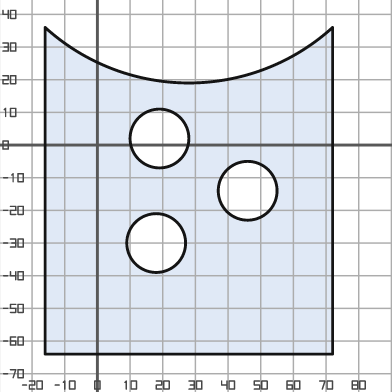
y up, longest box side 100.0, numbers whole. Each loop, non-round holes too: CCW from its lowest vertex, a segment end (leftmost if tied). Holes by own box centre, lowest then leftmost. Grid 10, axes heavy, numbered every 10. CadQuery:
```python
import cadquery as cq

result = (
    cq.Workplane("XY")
    .moveTo(-16.0, -64.0)
    .lineTo(72.0, -64.0)
    .lineTo(72.0, 36.0)
    .threePointArc((28.0, 19.0), (-16.0, 36.0))
    .close()
    .moveTo(18.0, -30.0)
    .circle(9.0)
    .moveTo(46.0, -14.0)
    .circle(9.0)
    .moveTo(19.0, 2.0)
    .circle(9.0)
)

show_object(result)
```